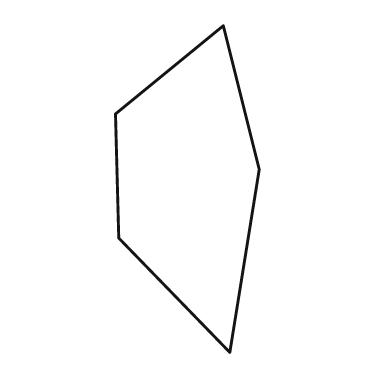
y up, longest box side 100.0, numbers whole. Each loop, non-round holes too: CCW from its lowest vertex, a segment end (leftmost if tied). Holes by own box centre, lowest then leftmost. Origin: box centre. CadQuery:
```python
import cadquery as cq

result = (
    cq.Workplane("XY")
    .moveTo(13.0, -50.0)
    .lineTo(22.0, 6.0)
    .lineTo(11.0, 50.0)
    .lineTo(-22.0, 23.0)
    .lineTo(-21.0, -15.0)
    .close()
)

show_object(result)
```